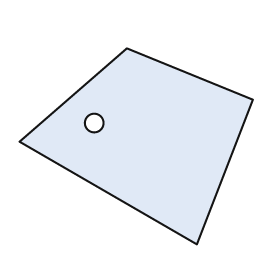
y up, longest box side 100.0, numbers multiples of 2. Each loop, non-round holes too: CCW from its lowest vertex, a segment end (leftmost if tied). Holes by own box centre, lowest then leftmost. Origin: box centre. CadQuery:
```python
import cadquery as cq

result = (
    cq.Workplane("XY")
    .moveTo(26.0, -42.0)
    .lineTo(50.0, 20.0)
    .lineTo(-4.0, 42.0)
    .lineTo(-50.0, 2.0)
    .close()
    .moveTo(-18.0, 10.0)
    .circle(4.0)
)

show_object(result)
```